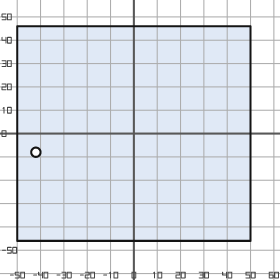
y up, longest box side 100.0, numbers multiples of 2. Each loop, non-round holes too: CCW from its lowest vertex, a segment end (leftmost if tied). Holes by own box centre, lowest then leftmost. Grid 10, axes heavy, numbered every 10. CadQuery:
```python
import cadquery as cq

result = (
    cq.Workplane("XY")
    .moveTo(-50.0, -46.0)
    .lineTo(50.0, -46.0)
    .lineTo(50.0, 46.0)
    .lineTo(-50.0, 46.0)
    .close()
    .moveTo(-42.0, -8.0)
    .circle(2.0)
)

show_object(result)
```